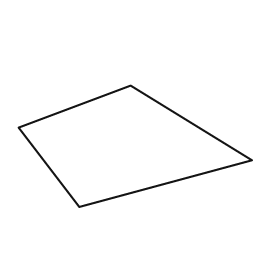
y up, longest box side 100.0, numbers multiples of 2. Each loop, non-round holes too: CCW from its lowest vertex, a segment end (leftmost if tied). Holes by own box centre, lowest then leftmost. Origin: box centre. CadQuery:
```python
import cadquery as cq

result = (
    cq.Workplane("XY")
    .moveTo(-24.0, -26.0)
    .lineTo(50.0, -6.0)
    .lineTo(-2.0, 26.0)
    .lineTo(-50.0, 8.0)
    .close()
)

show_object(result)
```